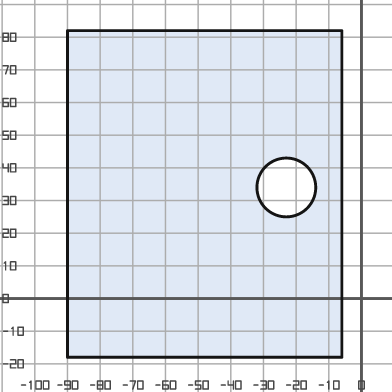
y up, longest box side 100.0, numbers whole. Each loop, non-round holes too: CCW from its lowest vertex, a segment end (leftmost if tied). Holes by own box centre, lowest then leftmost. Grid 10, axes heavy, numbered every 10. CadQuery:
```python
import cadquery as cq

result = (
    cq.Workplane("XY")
    .moveTo(-90.0, -18.0)
    .lineTo(-6.0, -18.0)
    .lineTo(-6.0, 82.0)
    .lineTo(-90.0, 82.0)
    .close()
    .moveTo(-23.0, 34.0)
    .circle(9.0)
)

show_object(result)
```